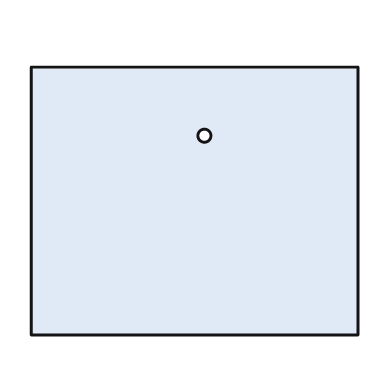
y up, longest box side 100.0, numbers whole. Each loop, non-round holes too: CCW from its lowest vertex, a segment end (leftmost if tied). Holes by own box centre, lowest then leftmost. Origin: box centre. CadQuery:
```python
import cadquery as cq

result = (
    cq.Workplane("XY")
    .moveTo(-50.0, -41.0)
    .lineTo(50.0, -41.0)
    .lineTo(50.0, 41.0)
    .lineTo(-50.0, 41.0)
    .close()
    .moveTo(3.0, 20.0)
    .circle(2.0)
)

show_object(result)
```